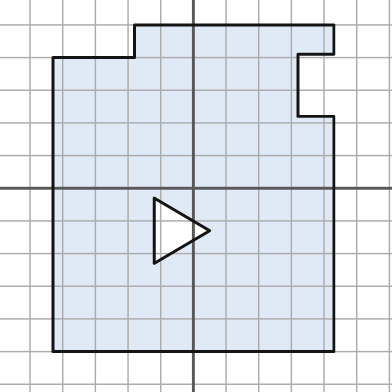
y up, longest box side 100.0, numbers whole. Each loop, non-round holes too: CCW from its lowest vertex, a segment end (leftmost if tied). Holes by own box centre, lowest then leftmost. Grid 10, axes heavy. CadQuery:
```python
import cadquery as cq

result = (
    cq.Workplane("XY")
    .moveTo(-43.0, -50.0)
    .lineTo(43.0, -50.0)
    .lineTo(43.0, 22.0)
    .lineTo(32.0, 22.0)
    .lineTo(32.0, 41.0)
    .lineTo(43.0, 41.0)
    .lineTo(43.0, 50.0)
    .lineTo(-18.0, 50.0)
    .lineTo(-18.0, 40.0)
    .lineTo(-43.0, 40.0)
    .close()
    .moveTo(-12.0, -23.0)
    .lineTo(5.0, -13.0)
    .lineTo(-12.0, -3.0)
    .close()
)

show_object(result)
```